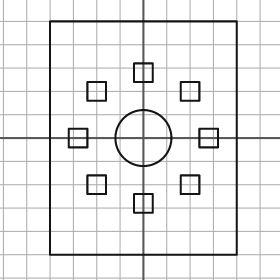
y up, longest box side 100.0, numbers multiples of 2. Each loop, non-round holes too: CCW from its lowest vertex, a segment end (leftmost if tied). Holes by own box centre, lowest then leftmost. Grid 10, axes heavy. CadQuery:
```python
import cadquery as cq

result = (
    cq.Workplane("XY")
    .moveTo(-40.0, -50.0)
    .lineTo(40.0, -50.0)
    .lineTo(40.0, 50.0)
    .lineTo(-40.0, 50.0)
    .close()
    .moveTo(-4.0, -32.0)
    .lineTo(4.0, -32.0)
    .lineTo(4.0, -24.0)
    .lineTo(-4.0, -24.0)
    .close()
    .moveTo(-24.0, -24.0)
    .lineTo(-16.0, -24.0)
    .lineTo(-16.0, -16.0)
    .lineTo(-24.0, -16.0)
    .close()
    .moveTo(16.0, -24.0)
    .lineTo(24.0, -24.0)
    .lineTo(24.0, -16.0)
    .lineTo(16.0, -16.0)
    .close()
    .moveTo(-32.0, -4.0)
    .lineTo(-24.0, -4.0)
    .lineTo(-24.0, 4.0)
    .lineTo(-32.0, 4.0)
    .close()
    .moveTo(0.0, 0.0)
    .circle(12.0)
    .moveTo(24.0, -4.0)
    .lineTo(32.0, -4.0)
    .lineTo(32.0, 4.0)
    .lineTo(24.0, 4.0)
    .close()
    .moveTo(-24.0, 16.0)
    .lineTo(-16.0, 16.0)
    .lineTo(-16.0, 24.0)
    .lineTo(-24.0, 24.0)
    .close()
    .moveTo(16.0, 16.0)
    .lineTo(24.0, 16.0)
    .lineTo(24.0, 24.0)
    .lineTo(16.0, 24.0)
    .close()
    .moveTo(-4.0, 24.0)
    .lineTo(4.0, 24.0)
    .lineTo(4.0, 32.0)
    .lineTo(-4.0, 32.0)
    .close()
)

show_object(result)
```